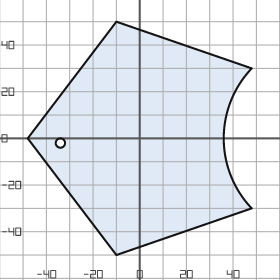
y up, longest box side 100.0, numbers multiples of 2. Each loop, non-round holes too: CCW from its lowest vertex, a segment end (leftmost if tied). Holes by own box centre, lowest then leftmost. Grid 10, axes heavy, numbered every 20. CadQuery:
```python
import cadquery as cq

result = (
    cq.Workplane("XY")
    .moveTo(-10.0, -50.0)
    .lineTo(48.0, -30.0)
    .threePointArc((36.0, 0.0), (48.0, 30.0))
    .lineTo(-10.0, 50.0)
    .lineTo(-48.0, 0.0)
    .close()
    .moveTo(-34.0, -2.0)
    .circle(2.0)
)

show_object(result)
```